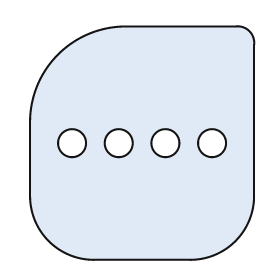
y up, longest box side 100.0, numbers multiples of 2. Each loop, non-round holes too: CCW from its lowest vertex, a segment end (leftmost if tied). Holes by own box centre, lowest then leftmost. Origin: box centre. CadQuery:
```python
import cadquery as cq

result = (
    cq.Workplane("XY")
    .moveTo(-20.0, -50.0)
    .lineTo(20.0, -50.0)
    .threePointArc((40.0, -42.0), (48.0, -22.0))
    .lineTo(48.0, 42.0)
    .threePointArc((46.0, 48.0), (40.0, 50.0))
    .lineTo(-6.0, 50.0)
    .threePointArc((-36.0, 38.0), (-48.0, 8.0))
    .lineTo(-48.0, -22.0)
    .threePointArc((-40.0, -42.0), (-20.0, -50.0))
    .close()
    .moveTo(-30.0, 0.0)
    .circle(6.0)
    .moveTo(-10.0, 0.0)
    .circle(6.0)
    .moveTo(10.0, 0.0)
    .circle(6.0)
    .moveTo(30.0, 0.0)
    .circle(6.0)
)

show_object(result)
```